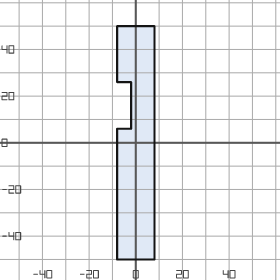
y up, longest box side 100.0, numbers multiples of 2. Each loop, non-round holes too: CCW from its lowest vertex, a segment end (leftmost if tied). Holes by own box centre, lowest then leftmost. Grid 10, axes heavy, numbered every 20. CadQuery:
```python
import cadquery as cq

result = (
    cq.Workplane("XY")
    .moveTo(-8.0, -50.0)
    .lineTo(8.0, -50.0)
    .lineTo(8.0, 50.0)
    .lineTo(-8.0, 50.0)
    .lineTo(-8.0, 26.0)
    .lineTo(-2.0, 26.0)
    .lineTo(-2.0, 6.0)
    .lineTo(-8.0, 6.0)
    .close()
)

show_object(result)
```